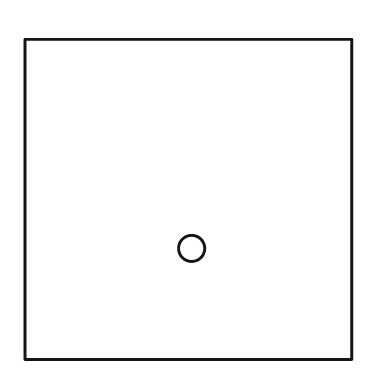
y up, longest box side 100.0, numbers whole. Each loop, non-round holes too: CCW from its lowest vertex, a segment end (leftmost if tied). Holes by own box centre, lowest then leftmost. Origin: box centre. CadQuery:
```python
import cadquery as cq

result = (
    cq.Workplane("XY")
    .moveTo(-50.0, -49.0)
    .lineTo(50.0, -49.0)
    .lineTo(50.0, 49.0)
    .lineTo(-50.0, 49.0)
    .close()
    .moveTo(1.0, -15.0)
    .circle(4.0)
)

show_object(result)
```